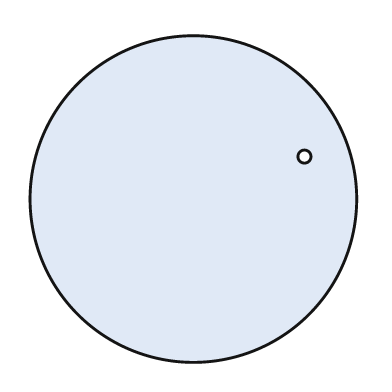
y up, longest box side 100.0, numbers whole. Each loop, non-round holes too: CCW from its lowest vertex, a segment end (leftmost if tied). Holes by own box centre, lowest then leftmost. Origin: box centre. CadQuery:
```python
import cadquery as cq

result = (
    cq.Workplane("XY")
    .moveTo(0.0, 0.0)
    .circle(50.0)
    .moveTo(34.0, 13.0)
    .circle(2.0)
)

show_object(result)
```